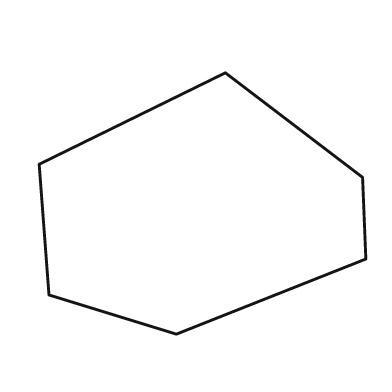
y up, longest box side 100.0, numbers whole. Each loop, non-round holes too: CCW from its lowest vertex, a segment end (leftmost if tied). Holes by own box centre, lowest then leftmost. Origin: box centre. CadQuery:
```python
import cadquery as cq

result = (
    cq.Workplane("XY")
    .moveTo(-8.0, -40.0)
    .lineTo(50.0, -17.0)
    .lineTo(49.0, 8.0)
    .lineTo(7.0, 40.0)
    .lineTo(-50.0, 12.0)
    .lineTo(-47.0, -28.0)
    .close()
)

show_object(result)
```